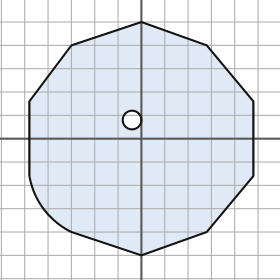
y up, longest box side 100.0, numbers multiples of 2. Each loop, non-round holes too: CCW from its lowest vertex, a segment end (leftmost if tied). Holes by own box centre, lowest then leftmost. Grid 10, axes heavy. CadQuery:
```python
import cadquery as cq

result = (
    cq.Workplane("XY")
    .moveTo(0.0, -50.0)
    .lineTo(28.0, -40.0)
    .lineTo(48.0, -16.0)
    .lineTo(48.0, 16.0)
    .lineTo(28.0, 40.0)
    .lineTo(0.0, 50.0)
    .lineTo(-30.0, 40.0)
    .lineTo(-48.0, 16.0)
    .lineTo(-48.0, -16.0)
    .threePointArc((-42.0, -30.0), (-30.0, -40.0))
    .close()
    .moveTo(-4.0, 8.0)
    .circle(4.0)
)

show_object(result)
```